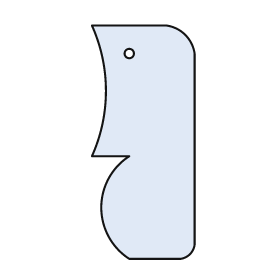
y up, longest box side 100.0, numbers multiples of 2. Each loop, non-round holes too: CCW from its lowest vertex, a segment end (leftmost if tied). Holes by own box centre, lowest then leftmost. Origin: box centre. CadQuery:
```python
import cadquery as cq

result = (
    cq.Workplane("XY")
    .moveTo(-6.0, -50.0)
    .lineTo(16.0, -50.0)
    .threePointArc((20.0, -48.0), (22.0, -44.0))
    .lineTo(22.0, 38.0)
    .threePointArc((18.0, 46.0), (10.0, 50.0))
    .lineTo(-22.0, 50.0)
    .threePointArc((-16.0, 22.0), (-22.0, -6.0))
    .lineTo(-6.0, -6.0)
    .threePointArc((-18.0, -28.0), (-6.0, -50.0))
    .close()
    .moveTo(-6.0, 38.0)
    .circle(2.0)
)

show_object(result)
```